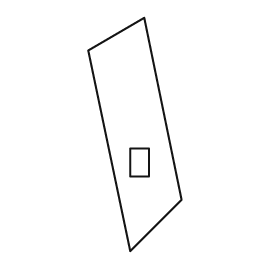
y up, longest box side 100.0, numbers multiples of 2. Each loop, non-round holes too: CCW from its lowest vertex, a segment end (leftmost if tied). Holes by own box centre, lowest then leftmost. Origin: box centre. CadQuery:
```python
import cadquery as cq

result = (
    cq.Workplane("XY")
    .moveTo(-2.0, -50.0)
    .lineTo(20.0, -28.0)
    .lineTo(4.0, 50.0)
    .lineTo(-20.0, 36.0)
    .close()
    .moveTo(-2.0, -18.0)
    .lineTo(6.0, -18.0)
    .lineTo(6.0, -6.0)
    .lineTo(-2.0, -6.0)
    .close()
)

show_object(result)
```